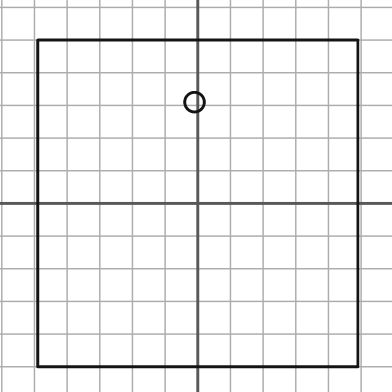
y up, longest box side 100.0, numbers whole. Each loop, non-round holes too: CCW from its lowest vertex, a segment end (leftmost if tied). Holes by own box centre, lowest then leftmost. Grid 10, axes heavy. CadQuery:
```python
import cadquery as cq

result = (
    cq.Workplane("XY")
    .moveTo(-49.0, -50.0)
    .lineTo(49.0, -50.0)
    .lineTo(49.0, 50.0)
    .lineTo(-49.0, 50.0)
    .close()
    .moveTo(-1.0, 31.0)
    .circle(3.0)
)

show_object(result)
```